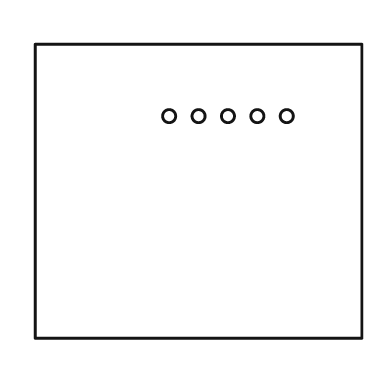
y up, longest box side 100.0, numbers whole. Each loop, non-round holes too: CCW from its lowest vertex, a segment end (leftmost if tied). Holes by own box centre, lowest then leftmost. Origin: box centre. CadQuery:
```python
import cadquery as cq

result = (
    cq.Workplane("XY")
    .moveTo(-50.0, -45.0)
    .lineTo(50.0, -45.0)
    .lineTo(50.0, 45.0)
    .lineTo(-50.0, 45.0)
    .close()
    .moveTo(-9.0, 23.0)
    .circle(2.0)
    .moveTo(0.0, 23.0)
    .circle(2.0)
    .moveTo(9.0, 23.0)
    .circle(2.0)
    .moveTo(18.0, 23.0)
    .circle(2.0)
    .moveTo(27.0, 23.0)
    .circle(2.0)
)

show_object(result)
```